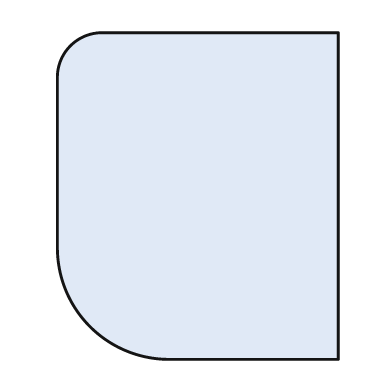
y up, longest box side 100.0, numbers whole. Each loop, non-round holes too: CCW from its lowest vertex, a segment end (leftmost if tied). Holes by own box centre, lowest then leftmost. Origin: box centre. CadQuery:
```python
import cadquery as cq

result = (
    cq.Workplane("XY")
    .moveTo(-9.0, -50.0)
    .lineTo(43.0, -50.0)
    .lineTo(43.0, 50.0)
    .lineTo(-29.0, 50.0)
    .threePointArc((-39.0, 46.0), (-43.0, 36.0))
    .lineTo(-43.0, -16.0)
    .threePointArc((-33.0, -40.0), (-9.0, -50.0))
    .close()
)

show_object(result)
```